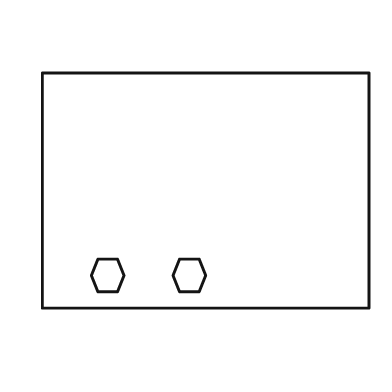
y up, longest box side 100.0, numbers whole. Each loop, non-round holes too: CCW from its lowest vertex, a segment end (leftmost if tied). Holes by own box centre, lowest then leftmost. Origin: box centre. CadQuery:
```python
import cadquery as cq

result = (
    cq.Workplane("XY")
    .moveTo(-50.0, -36.0)
    .lineTo(50.0, -36.0)
    .lineTo(50.0, 36.0)
    .lineTo(-50.0, 36.0)
    .close()
    .moveTo(-33.0, -31.0)
    .lineTo(-27.0, -31.0)
    .lineTo(-25.0, -26.0)
    .lineTo(-27.0, -21.0)
    .lineTo(-33.0, -21.0)
    .lineTo(-35.0, -26.0)
    .close()
    .moveTo(-8.0, -31.0)
    .lineTo(-2.0, -31.0)
    .lineTo(0.0, -26.0)
    .lineTo(-2.0, -21.0)
    .lineTo(-8.0, -21.0)
    .lineTo(-10.0, -26.0)
    .close()
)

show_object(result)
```